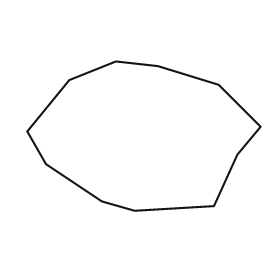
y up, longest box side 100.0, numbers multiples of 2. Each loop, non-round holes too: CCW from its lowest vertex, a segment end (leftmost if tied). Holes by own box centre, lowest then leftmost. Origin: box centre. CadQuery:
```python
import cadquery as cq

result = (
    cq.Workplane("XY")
    .moveTo(-4.0, -32.0)
    .lineTo(30.0, -30.0)
    .lineTo(40.0, -8.0)
    .lineTo(50.0, 4.0)
    .lineTo(32.0, 22.0)
    .lineTo(6.0, 30.0)
    .lineTo(-12.0, 32.0)
    .lineTo(-32.0, 24.0)
    .lineTo(-50.0, 2.0)
    .lineTo(-42.0, -12.0)
    .lineTo(-18.0, -28.0)
    .close()
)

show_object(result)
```